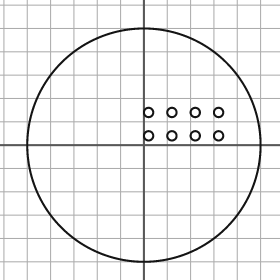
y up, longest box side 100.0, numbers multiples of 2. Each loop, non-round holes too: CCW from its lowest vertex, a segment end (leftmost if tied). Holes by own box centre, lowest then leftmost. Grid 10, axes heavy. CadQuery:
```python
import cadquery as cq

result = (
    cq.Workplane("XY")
    .moveTo(0.0, 0.0)
    .circle(50.0)
    .moveTo(2.0, 4.0)
    .circle(2.0)
    .moveTo(12.0, 4.0)
    .circle(2.0)
    .moveTo(22.0, 4.0)
    .circle(2.0)
    .moveTo(32.0, 4.0)
    .circle(2.0)
    .moveTo(2.0, 14.0)
    .circle(2.0)
    .moveTo(12.0, 14.0)
    .circle(2.0)
    .moveTo(22.0, 14.0)
    .circle(2.0)
    .moveTo(32.0, 14.0)
    .circle(2.0)
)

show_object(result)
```